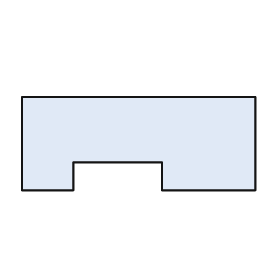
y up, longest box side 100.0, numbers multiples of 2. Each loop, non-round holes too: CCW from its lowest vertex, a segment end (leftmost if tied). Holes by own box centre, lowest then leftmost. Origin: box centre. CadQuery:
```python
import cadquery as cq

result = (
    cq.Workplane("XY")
    .moveTo(-50.0, -20.0)
    .lineTo(-28.0, -20.0)
    .lineTo(-28.0, -8.0)
    .lineTo(10.0, -8.0)
    .lineTo(10.0, -20.0)
    .lineTo(50.0, -20.0)
    .lineTo(50.0, 20.0)
    .lineTo(-50.0, 20.0)
    .close()
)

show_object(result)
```